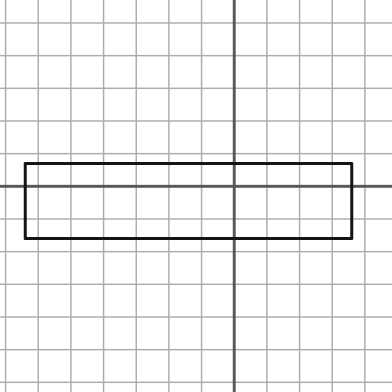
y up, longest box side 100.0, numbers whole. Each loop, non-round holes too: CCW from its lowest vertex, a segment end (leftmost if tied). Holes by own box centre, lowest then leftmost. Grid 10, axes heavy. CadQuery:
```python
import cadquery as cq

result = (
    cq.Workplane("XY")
    .moveTo(-64.0, -16.0)
    .lineTo(36.0, -16.0)
    .lineTo(36.0, 7.0)
    .lineTo(-64.0, 7.0)
    .close()
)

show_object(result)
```